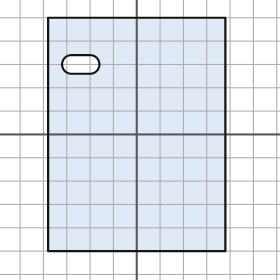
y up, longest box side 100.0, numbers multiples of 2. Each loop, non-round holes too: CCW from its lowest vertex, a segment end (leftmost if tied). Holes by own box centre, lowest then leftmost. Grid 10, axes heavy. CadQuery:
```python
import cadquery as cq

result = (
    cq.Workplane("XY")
    .moveTo(-38.0, -50.0)
    .lineTo(38.0, -50.0)
    .lineTo(38.0, 50.0)
    .lineTo(-38.0, 50.0)
    .close()
    .moveTo(-28.0, 26.0)
    .lineTo(-20.0, 26.0)
    .threePointArc((-16.0, 30.0), (-20.0, 34.0))
    .lineTo(-28.0, 34.0)
    .threePointArc((-32.0, 30.0), (-28.0, 26.0))
    .close()
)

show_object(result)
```